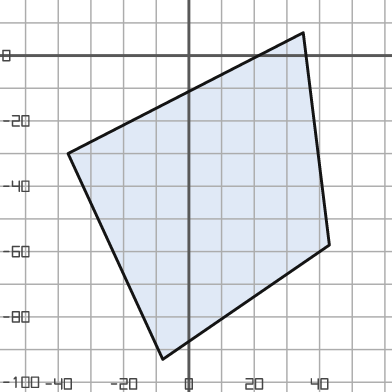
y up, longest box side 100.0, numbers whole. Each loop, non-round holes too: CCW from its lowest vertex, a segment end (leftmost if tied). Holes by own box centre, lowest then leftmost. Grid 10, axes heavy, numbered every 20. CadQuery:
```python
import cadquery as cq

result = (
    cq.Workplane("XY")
    .moveTo(-8.0, -93.0)
    .lineTo(43.0, -58.0)
    .lineTo(35.0, 7.0)
    .lineTo(-37.0, -30.0)
    .close()
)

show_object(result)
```